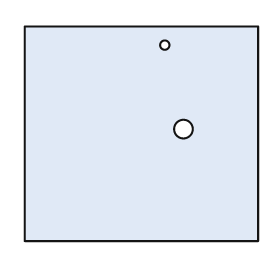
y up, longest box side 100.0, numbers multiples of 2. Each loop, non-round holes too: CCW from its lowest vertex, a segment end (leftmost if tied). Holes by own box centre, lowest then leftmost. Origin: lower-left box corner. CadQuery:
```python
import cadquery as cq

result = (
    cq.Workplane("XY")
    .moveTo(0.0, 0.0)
    .lineTo(100.0, 0.0)
    .lineTo(100.0, 92.0)
    .lineTo(0.0, 92.0)
    .close()
    .moveTo(68.0, 48.0)
    .circle(4.0)
    .moveTo(60.0, 84.0)
    .circle(2.0)
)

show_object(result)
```